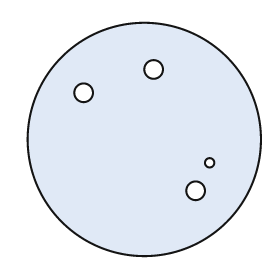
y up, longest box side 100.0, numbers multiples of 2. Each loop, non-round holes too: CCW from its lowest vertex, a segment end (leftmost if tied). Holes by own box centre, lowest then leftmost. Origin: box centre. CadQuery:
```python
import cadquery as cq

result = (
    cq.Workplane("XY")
    .moveTo(0.0, 0.0)
    .circle(50.0)
    .moveTo(22.0, -22.0)
    .circle(4.0)
    .moveTo(28.0, -10.0)
    .circle(2.0)
    .moveTo(-26.0, 20.0)
    .circle(4.0)
    .moveTo(4.0, 30.0)
    .circle(4.0)
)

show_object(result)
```